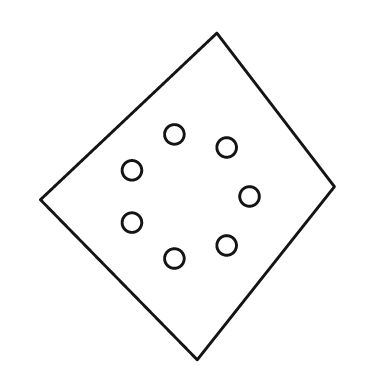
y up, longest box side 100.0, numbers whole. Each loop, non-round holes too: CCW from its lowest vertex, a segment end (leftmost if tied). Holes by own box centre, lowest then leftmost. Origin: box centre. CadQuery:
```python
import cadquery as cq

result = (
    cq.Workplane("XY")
    .moveTo(3.0, -50.0)
    .lineTo(45.0, 3.0)
    .lineTo(9.0, 50.0)
    .lineTo(-45.0, -1.0)
    .close()
    .moveTo(-4.0, -19.0)
    .circle(3.0)
    .moveTo(12.0, -15.0)
    .circle(3.0)
    .moveTo(-17.0, -8.0)
    .circle(3.0)
    .moveTo(19.0, 0.0)
    .circle(3.0)
    .moveTo(-17.0, 8.0)
    .circle(3.0)
    .moveTo(12.0, 15.0)
    .circle(3.0)
    .moveTo(-4.0, 19.0)
    .circle(3.0)
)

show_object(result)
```